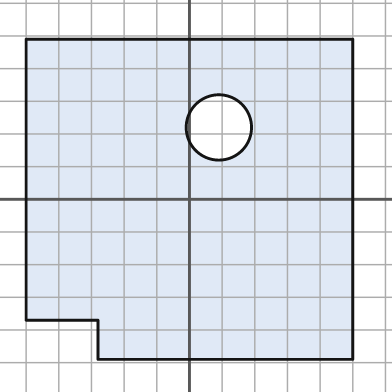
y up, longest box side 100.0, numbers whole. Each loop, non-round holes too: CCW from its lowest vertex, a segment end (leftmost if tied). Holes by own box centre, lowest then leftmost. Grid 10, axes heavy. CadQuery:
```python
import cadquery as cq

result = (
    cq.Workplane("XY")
    .moveTo(-28.0, -49.0)
    .lineTo(50.0, -49.0)
    .lineTo(50.0, 49.0)
    .lineTo(-50.0, 49.0)
    .lineTo(-50.0, -37.0)
    .lineTo(-28.0, -37.0)
    .close()
    .moveTo(9.0, 22.0)
    .circle(10.0)
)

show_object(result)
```